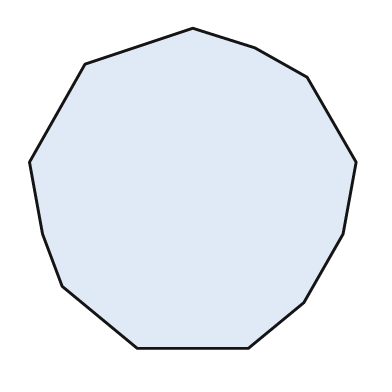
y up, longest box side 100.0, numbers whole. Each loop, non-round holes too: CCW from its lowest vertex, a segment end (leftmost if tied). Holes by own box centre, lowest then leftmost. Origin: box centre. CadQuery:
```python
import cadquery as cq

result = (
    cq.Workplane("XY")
    .moveTo(-17.0, -49.0)
    .lineTo(17.0, -49.0)
    .lineTo(34.0, -35.0)
    .lineTo(46.0, -14.0)
    .lineTo(50.0, 8.0)
    .lineTo(35.0, 34.0)
    .lineTo(19.0, 43.0)
    .lineTo(0.0, 49.0)
    .lineTo(-33.0, 38.0)
    .lineTo(-50.0, 8.0)
    .lineTo(-46.0, -14.0)
    .lineTo(-40.0, -30.0)
    .close()
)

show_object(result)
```